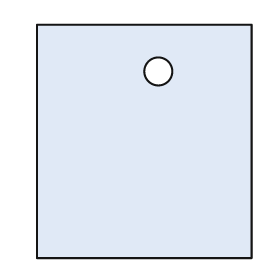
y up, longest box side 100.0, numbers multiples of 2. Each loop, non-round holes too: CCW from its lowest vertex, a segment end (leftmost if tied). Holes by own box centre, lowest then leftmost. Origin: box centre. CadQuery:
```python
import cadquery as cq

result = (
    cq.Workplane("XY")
    .moveTo(-46.0, -50.0)
    .lineTo(46.0, -50.0)
    .lineTo(46.0, 50.0)
    .lineTo(-46.0, 50.0)
    .close()
    .moveTo(6.0, 30.0)
    .circle(6.0)
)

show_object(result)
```